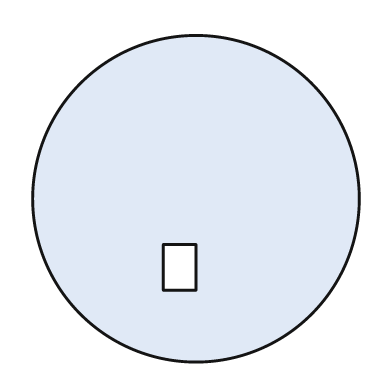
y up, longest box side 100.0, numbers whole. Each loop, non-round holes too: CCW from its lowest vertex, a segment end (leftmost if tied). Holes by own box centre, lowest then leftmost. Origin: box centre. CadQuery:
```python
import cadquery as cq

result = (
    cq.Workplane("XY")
    .moveTo(0.0, 0.0)
    .circle(50.0)
    .moveTo(-10.0, -28.0)
    .lineTo(0.0, -28.0)
    .lineTo(0.0, -14.0)
    .lineTo(-10.0, -14.0)
    .close()
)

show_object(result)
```